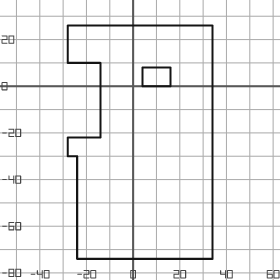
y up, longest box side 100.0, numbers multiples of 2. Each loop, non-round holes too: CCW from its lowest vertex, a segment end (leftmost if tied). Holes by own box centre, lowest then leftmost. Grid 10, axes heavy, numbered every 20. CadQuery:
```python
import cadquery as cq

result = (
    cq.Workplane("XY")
    .moveTo(-24.0, -74.0)
    .lineTo(34.0, -74.0)
    .lineTo(34.0, 26.0)
    .lineTo(-28.0, 26.0)
    .lineTo(-28.0, 10.0)
    .lineTo(-14.0, 10.0)
    .lineTo(-14.0, -22.0)
    .lineTo(-28.0, -22.0)
    .lineTo(-28.0, -30.0)
    .lineTo(-24.0, -30.0)
    .close()
    .moveTo(4.0, 0.0)
    .lineTo(16.0, 0.0)
    .lineTo(16.0, 8.0)
    .lineTo(4.0, 8.0)
    .close()
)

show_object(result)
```